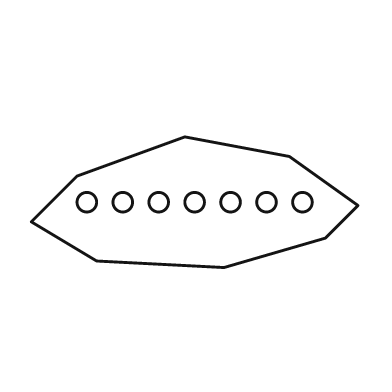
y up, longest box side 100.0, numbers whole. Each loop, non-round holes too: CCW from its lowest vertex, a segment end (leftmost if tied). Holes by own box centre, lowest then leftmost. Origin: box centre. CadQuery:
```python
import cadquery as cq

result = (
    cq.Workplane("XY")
    .moveTo(9.0, -20.0)
    .lineTo(40.0, -11.0)
    .lineTo(50.0, -1.0)
    .lineTo(29.0, 14.0)
    .lineTo(-3.0, 20.0)
    .lineTo(-36.0, 8.0)
    .lineTo(-50.0, -6.0)
    .lineTo(-30.0, -18.0)
    .close()
    .moveTo(-33.0, 0.0)
    .circle(3.0)
    .moveTo(-22.0, 0.0)
    .circle(3.0)
    .moveTo(-11.0, 0.0)
    .circle(3.0)
    .moveTo(0.0, 0.0)
    .circle(3.0)
    .moveTo(11.0, 0.0)
    .circle(3.0)
    .moveTo(22.0, 0.0)
    .circle(3.0)
    .moveTo(33.0, 0.0)
    .circle(3.0)
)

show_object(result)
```